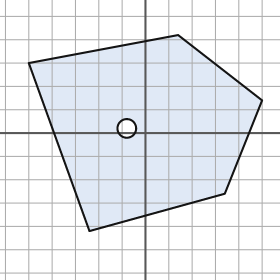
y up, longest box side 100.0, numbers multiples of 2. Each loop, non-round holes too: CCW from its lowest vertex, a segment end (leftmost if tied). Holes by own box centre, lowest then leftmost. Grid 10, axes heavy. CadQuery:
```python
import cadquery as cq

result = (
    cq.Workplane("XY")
    .moveTo(-24.0, -42.0)
    .lineTo(34.0, -26.0)
    .lineTo(50.0, 14.0)
    .lineTo(14.0, 42.0)
    .lineTo(-50.0, 30.0)
    .close()
    .moveTo(-8.0, 2.0)
    .circle(4.0)
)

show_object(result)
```